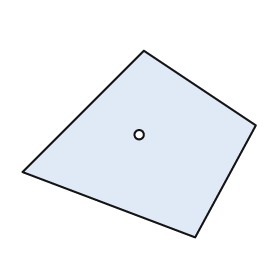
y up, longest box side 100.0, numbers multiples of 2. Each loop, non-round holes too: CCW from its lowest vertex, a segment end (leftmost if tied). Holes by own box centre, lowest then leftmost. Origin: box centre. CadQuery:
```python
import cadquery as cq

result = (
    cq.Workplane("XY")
    .moveTo(24.0, -40.0)
    .lineTo(50.0, 8.0)
    .lineTo(2.0, 40.0)
    .lineTo(-50.0, -12.0)
    .close()
    .moveTo(0.0, 4.0)
    .circle(2.0)
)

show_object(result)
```